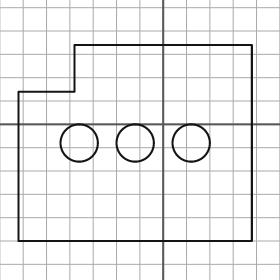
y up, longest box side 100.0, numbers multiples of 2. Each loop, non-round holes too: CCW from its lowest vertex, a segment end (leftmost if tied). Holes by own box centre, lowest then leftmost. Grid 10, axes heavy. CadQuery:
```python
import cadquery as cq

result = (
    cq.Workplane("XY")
    .moveTo(-62.0, -50.0)
    .lineTo(38.0, -50.0)
    .lineTo(38.0, 34.0)
    .lineTo(-38.0, 34.0)
    .lineTo(-38.0, 14.0)
    .lineTo(-62.0, 14.0)
    .close()
    .moveTo(-36.0, -8.0)
    .circle(8.0)
    .moveTo(-12.0, -8.0)
    .circle(8.0)
    .moveTo(12.0, -8.0)
    .circle(8.0)
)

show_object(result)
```